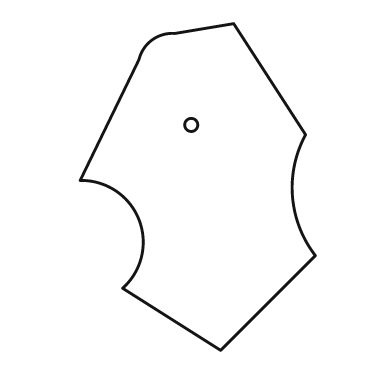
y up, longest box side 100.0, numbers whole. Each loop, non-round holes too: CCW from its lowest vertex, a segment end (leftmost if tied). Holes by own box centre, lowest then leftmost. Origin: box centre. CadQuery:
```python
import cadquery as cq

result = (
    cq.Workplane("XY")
    .moveTo(7.0, -50.0)
    .lineTo(36.0, -21.0)
    .threePointArc((29.0, -3.0), (33.0, 16.0))
    .lineTo(11.0, 50.0)
    .lineTo(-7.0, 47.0)
    .threePointArc((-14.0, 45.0), (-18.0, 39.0))
    .lineTo(-36.0, 2.0)
    .threePointArc((-18.0, -10.0), (-23.0, -31.0))
    .close()
    .moveTo(-2.0, 19.0)
    .circle(2.0)
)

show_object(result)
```